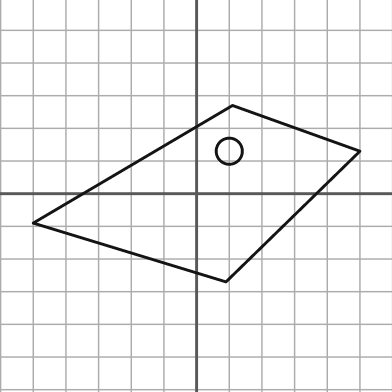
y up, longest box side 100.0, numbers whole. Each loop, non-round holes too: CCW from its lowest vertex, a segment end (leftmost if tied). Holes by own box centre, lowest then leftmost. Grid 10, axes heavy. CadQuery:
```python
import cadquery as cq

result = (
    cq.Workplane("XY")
    .moveTo(9.0, -27.0)
    .lineTo(50.0, 13.0)
    .lineTo(11.0, 27.0)
    .lineTo(-50.0, -9.0)
    .close()
    .moveTo(10.0, 13.0)
    .circle(4.0)
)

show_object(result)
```